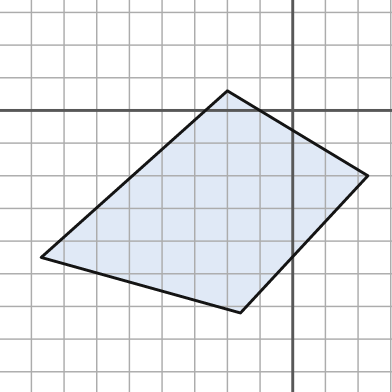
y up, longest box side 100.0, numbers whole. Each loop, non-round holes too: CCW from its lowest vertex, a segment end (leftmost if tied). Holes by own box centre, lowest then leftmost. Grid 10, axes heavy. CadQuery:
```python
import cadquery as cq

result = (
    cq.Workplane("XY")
    .moveTo(-16.0, -62.0)
    .lineTo(23.0, -20.0)
    .lineTo(-20.0, 6.0)
    .lineTo(-77.0, -45.0)
    .close()
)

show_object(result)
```